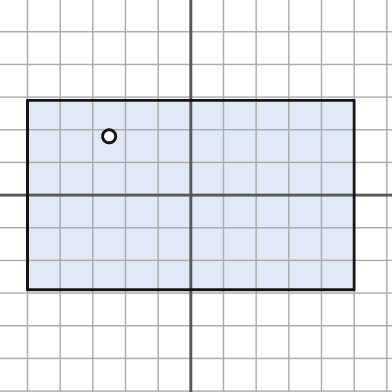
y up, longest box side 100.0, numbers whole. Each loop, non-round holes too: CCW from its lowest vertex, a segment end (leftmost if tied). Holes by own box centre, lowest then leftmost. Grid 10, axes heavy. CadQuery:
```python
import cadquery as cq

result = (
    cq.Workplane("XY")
    .moveTo(-50.0, -29.0)
    .lineTo(50.0, -29.0)
    .lineTo(50.0, 29.0)
    .lineTo(-50.0, 29.0)
    .close()
    .moveTo(-25.0, 18.0)
    .circle(2.0)
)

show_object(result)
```